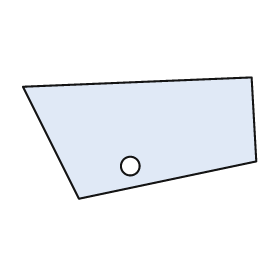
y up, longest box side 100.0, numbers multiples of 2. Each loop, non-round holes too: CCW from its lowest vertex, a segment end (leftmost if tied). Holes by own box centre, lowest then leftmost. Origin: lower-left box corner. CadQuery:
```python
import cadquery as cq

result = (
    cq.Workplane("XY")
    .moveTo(24.0, 0.0)
    .lineTo(100.0, 16.0)
    .lineTo(98.0, 52.0)
    .lineTo(0.0, 48.0)
    .close()
    .moveTo(46.0, 14.0)
    .circle(4.0)
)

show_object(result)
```